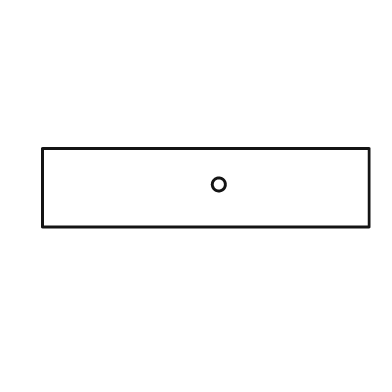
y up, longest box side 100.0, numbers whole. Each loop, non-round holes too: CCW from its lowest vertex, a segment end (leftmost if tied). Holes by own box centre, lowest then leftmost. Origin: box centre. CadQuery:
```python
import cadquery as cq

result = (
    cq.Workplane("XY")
    .moveTo(-50.0, -12.0)
    .lineTo(50.0, -12.0)
    .lineTo(50.0, 12.0)
    .lineTo(-50.0, 12.0)
    .close()
    .moveTo(4.0, 1.0)
    .circle(2.0)
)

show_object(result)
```